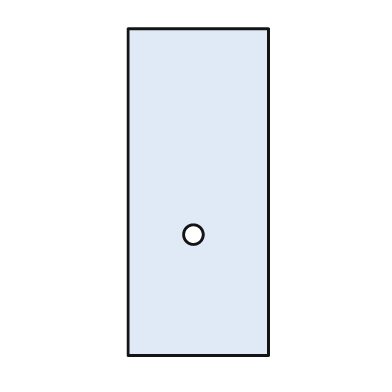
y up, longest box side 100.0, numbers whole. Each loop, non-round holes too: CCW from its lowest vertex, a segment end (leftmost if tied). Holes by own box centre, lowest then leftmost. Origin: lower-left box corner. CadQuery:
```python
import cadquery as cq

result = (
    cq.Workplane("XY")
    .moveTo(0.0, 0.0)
    .lineTo(43.0, 0.0)
    .lineTo(43.0, 100.0)
    .lineTo(0.0, 100.0)
    .close()
    .moveTo(20.0, 37.0)
    .circle(3.0)
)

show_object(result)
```